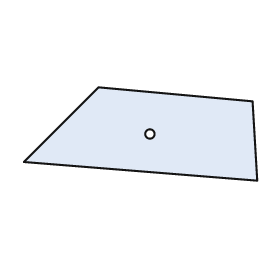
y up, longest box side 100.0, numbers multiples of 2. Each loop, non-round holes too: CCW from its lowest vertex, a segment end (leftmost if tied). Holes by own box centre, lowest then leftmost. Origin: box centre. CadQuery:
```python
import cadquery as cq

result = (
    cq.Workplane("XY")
    .moveTo(50.0, -20.0)
    .lineTo(48.0, 14.0)
    .lineTo(-18.0, 20.0)
    .lineTo(-50.0, -12.0)
    .close()
    .moveTo(4.0, 0.0)
    .circle(2.0)
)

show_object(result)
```